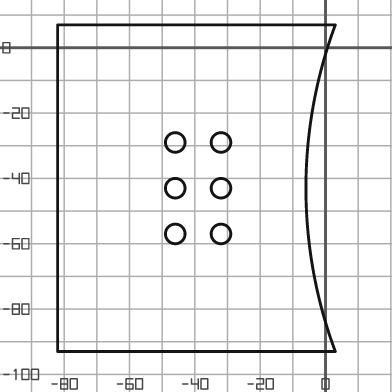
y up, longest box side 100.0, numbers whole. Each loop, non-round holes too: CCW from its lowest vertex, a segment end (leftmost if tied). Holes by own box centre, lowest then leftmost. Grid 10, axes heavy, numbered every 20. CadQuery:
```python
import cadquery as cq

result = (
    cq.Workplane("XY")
    .moveTo(-82.0, -93.0)
    .lineTo(3.0, -93.0)
    .threePointArc((-6.0, -43.0), (3.0, 7.0))
    .lineTo(-82.0, 7.0)
    .close()
    .moveTo(-46.0, -57.0)
    .circle(3.0)
    .moveTo(-32.0, -57.0)
    .circle(3.0)
    .moveTo(-46.0, -43.0)
    .circle(3.0)
    .moveTo(-32.0, -43.0)
    .circle(3.0)
    .moveTo(-46.0, -29.0)
    .circle(3.0)
    .moveTo(-32.0, -29.0)
    .circle(3.0)
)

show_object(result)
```